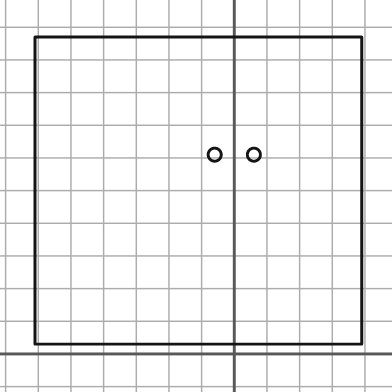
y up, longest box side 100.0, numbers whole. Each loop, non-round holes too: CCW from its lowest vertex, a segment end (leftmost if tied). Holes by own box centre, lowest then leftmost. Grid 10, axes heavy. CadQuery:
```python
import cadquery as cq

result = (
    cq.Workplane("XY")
    .moveTo(-61.0, 3.0)
    .lineTo(39.0, 3.0)
    .lineTo(39.0, 97.0)
    .lineTo(-61.0, 97.0)
    .close()
    .moveTo(-6.0, 61.0)
    .circle(2.0)
    .moveTo(6.0, 61.0)
    .circle(2.0)
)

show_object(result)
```